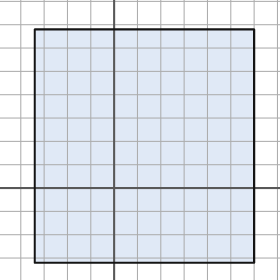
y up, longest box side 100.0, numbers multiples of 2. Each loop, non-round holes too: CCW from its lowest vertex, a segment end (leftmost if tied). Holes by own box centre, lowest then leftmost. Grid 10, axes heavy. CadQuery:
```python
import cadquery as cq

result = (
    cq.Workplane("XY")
    .moveTo(-34.0, -32.0)
    .lineTo(60.0, -32.0)
    .lineTo(60.0, 68.0)
    .lineTo(-34.0, 68.0)
    .close()
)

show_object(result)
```